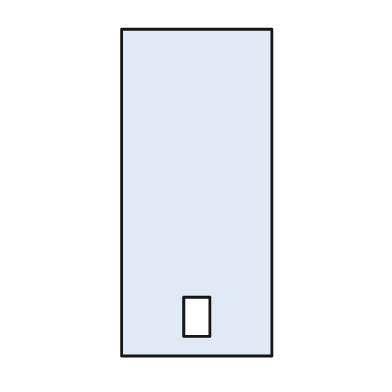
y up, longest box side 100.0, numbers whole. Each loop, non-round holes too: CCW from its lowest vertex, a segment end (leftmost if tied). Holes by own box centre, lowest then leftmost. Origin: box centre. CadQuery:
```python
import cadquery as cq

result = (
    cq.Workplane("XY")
    .moveTo(-23.0, -50.0)
    .lineTo(23.0, -50.0)
    .lineTo(23.0, 50.0)
    .lineTo(-23.0, 50.0)
    .close()
    .moveTo(-4.0, -44.0)
    .lineTo(4.0, -44.0)
    .lineTo(4.0, -32.0)
    .lineTo(-4.0, -32.0)
    .close()
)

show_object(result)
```